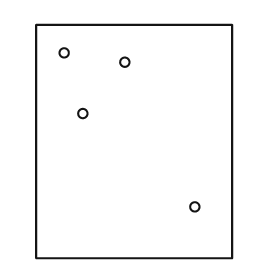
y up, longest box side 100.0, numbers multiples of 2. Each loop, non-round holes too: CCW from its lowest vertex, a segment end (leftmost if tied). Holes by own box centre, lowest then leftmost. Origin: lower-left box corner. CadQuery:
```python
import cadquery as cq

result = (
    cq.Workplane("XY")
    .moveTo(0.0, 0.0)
    .lineTo(84.0, 0.0)
    .lineTo(84.0, 100.0)
    .lineTo(0.0, 100.0)
    .close()
    .moveTo(68.0, 22.0)
    .circle(2.0)
    .moveTo(20.0, 62.0)
    .circle(2.0)
    .moveTo(38.0, 84.0)
    .circle(2.0)
    .moveTo(12.0, 88.0)
    .circle(2.0)
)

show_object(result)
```